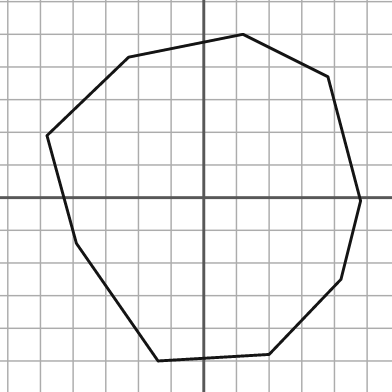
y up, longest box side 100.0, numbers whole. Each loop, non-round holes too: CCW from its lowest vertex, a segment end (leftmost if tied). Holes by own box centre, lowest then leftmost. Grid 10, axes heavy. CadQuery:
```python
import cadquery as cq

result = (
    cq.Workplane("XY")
    .moveTo(-14.0, -50.0)
    .lineTo(20.0, -48.0)
    .lineTo(42.0, -25.0)
    .lineTo(48.0, -1.0)
    .lineTo(38.0, 37.0)
    .lineTo(12.0, 50.0)
    .lineTo(-23.0, 43.0)
    .lineTo(-48.0, 19.0)
    .lineTo(-39.0, -14.0)
    .close()
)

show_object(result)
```